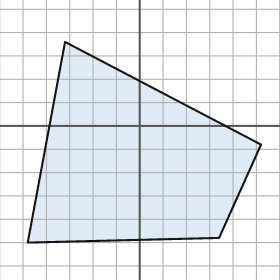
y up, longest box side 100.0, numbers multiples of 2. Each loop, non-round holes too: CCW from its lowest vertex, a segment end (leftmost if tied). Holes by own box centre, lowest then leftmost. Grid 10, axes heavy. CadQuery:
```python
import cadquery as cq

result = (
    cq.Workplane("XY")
    .moveTo(-48.0, -50.0)
    .lineTo(34.0, -48.0)
    .lineTo(52.0, -8.0)
    .lineTo(-32.0, 36.0)
    .close()
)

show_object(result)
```